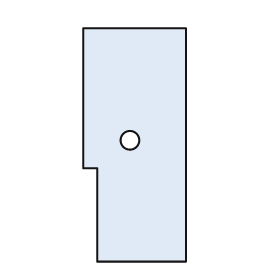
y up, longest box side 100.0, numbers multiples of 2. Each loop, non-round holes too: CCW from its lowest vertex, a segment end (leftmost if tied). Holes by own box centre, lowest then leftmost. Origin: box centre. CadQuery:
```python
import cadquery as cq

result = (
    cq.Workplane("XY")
    .moveTo(-16.0, -50.0)
    .lineTo(22.0, -50.0)
    .lineTo(22.0, 50.0)
    .lineTo(-22.0, 50.0)
    .lineTo(-22.0, -10.0)
    .lineTo(-16.0, -10.0)
    .close()
    .moveTo(-2.0, 2.0)
    .circle(4.0)
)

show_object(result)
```